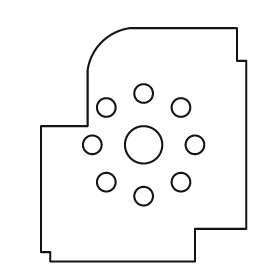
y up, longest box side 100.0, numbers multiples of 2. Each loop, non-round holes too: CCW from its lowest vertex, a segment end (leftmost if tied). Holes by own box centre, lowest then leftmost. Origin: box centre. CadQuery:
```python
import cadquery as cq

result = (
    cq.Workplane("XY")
    .moveTo(-40.0, -50.0)
    .lineTo(22.0, -50.0)
    .lineTo(22.0, -36.0)
    .lineTo(44.0, -36.0)
    .lineTo(44.0, 36.0)
    .lineTo(40.0, 36.0)
    .lineTo(40.0, 50.0)
    .lineTo(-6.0, 50.0)
    .threePointArc((-18.0, 44.0), (-24.0, 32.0))
    .lineTo(-24.0, 8.0)
    .lineTo(-44.0, 8.0)
    .lineTo(-44.0, -46.0)
    .lineTo(-40.0, -46.0)
    .close()
    .moveTo(0.0, -22.0)
    .circle(4.0)
    .moveTo(-16.0, -16.0)
    .circle(4.0)
    .moveTo(16.0, -16.0)
    .circle(4.0)
    .moveTo(-22.0, 0.0)
    .circle(4.0)
    .moveTo(0.0, 0.0)
    .circle(8.0)
    .moveTo(22.0, 0.0)
    .circle(4.0)
    .moveTo(-16.0, 16.0)
    .circle(4.0)
    .moveTo(16.0, 16.0)
    .circle(4.0)
    .moveTo(0.0, 22.0)
    .circle(4.0)
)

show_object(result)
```